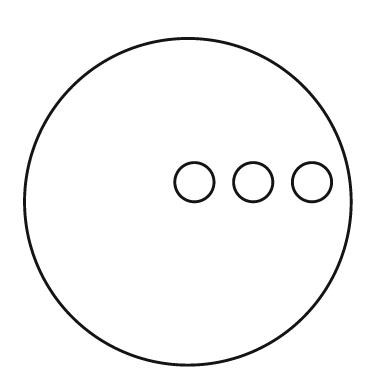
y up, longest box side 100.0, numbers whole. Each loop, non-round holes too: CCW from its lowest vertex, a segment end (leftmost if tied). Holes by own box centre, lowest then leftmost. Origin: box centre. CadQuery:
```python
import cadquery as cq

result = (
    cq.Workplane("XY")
    .moveTo(0.0, 0.0)
    .circle(50.0)
    .moveTo(2.0, 6.0)
    .circle(6.0)
    .moveTo(20.0, 6.0)
    .circle(6.0)
    .moveTo(38.0, 6.0)
    .circle(6.0)
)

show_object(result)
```